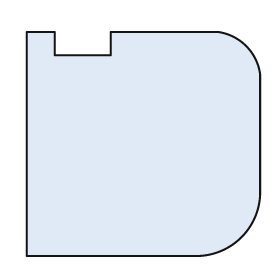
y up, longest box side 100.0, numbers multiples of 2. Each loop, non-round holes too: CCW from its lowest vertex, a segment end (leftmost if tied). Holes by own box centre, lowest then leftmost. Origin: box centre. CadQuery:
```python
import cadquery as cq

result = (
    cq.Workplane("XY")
    .moveTo(-50.0, -48.0)
    .lineTo(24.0, -48.0)
    .threePointArc((42.0, -40.0), (50.0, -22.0))
    .lineTo(50.0, 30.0)
    .threePointArc((44.0, 42.0), (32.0, 48.0))
    .lineTo(-14.0, 48.0)
    .lineTo(-14.0, 38.0)
    .lineTo(-38.0, 38.0)
    .lineTo(-38.0, 48.0)
    .lineTo(-50.0, 48.0)
    .close()
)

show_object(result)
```